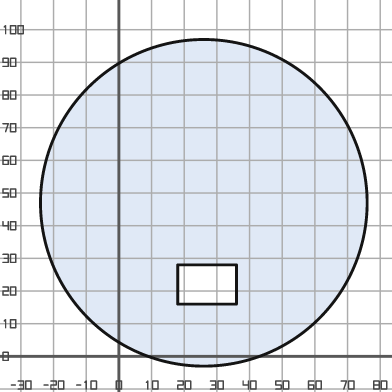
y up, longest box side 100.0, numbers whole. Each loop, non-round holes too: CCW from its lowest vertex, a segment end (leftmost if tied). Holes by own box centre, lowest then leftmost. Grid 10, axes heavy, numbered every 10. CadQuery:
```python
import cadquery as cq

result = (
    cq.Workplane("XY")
    .moveTo(26.0, 47.0)
    .circle(50.0)
    .moveTo(18.0, 16.0)
    .lineTo(36.0, 16.0)
    .lineTo(36.0, 28.0)
    .lineTo(18.0, 28.0)
    .close()
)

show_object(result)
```